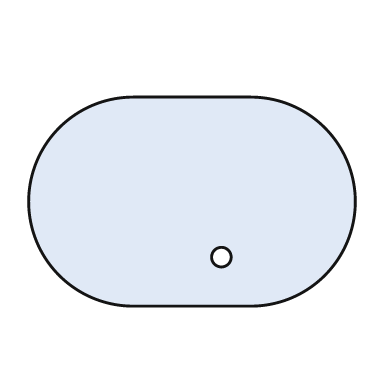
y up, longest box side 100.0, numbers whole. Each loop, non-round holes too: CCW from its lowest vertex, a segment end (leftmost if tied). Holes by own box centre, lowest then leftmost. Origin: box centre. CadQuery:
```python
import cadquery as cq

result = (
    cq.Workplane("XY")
    .moveTo(-18.0, -32.0)
    .lineTo(18.0, -32.0)
    .threePointArc((50.0, 0.0), (18.0, 32.0))
    .lineTo(-18.0, 32.0)
    .threePointArc((-50.0, 0.0), (-18.0, -32.0))
    .close()
    .moveTo(9.0, -17.0)
    .circle(3.0)
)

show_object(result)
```